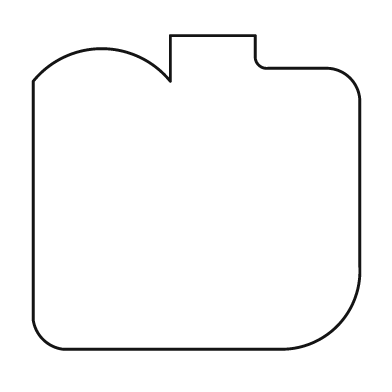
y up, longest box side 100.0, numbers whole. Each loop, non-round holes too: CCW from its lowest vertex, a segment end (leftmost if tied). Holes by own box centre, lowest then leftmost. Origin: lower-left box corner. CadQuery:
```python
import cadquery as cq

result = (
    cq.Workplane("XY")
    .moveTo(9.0, 0.0)
    .lineTo(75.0, 0.0)
    .threePointArc((93.0, 7.0), (100.0, 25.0))
    .lineTo(100.0, 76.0)
    .threePointArc((97.0, 83.0), (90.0, 86.0))
    .lineTo(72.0, 86.0)
    .threePointArc((69.0, 87.0), (68.0, 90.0))
    .lineTo(68.0, 96.0)
    .lineTo(42.0, 96.0)
    .lineTo(42.0, 82.0)
    .threePointArc((21.0, 92.0), (0.0, 82.0))
    .lineTo(0.0, 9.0)
    .threePointArc((3.0, 3.0), (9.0, 0.0))
    .close()
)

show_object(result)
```